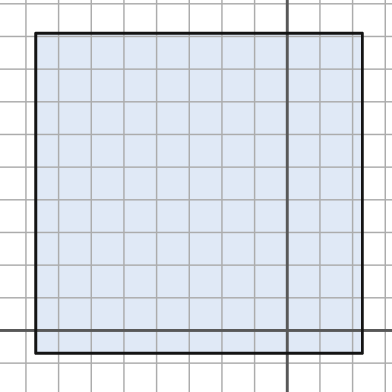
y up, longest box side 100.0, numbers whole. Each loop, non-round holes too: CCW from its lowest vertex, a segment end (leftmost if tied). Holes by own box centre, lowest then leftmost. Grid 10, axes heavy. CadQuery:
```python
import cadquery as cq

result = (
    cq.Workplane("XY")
    .moveTo(-77.0, -7.0)
    .lineTo(23.0, -7.0)
    .lineTo(23.0, 91.0)
    .lineTo(-77.0, 91.0)
    .close()
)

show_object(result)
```